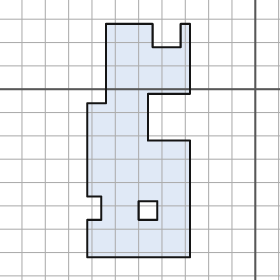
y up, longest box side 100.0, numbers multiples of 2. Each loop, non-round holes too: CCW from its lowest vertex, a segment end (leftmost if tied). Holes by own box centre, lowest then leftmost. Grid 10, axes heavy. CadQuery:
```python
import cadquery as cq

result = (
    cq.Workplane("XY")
    .moveTo(-72.0, -72.0)
    .lineTo(-28.0, -72.0)
    .lineTo(-28.0, -22.0)
    .lineTo(-46.0, -22.0)
    .lineTo(-46.0, -2.0)
    .lineTo(-28.0, -2.0)
    .lineTo(-28.0, 28.0)
    .lineTo(-32.0, 28.0)
    .lineTo(-32.0, 18.0)
    .lineTo(-44.0, 18.0)
    .lineTo(-44.0, 28.0)
    .lineTo(-64.0, 28.0)
    .lineTo(-64.0, -6.0)
    .lineTo(-72.0, -6.0)
    .lineTo(-72.0, -46.0)
    .lineTo(-66.0, -46.0)
    .lineTo(-66.0, -56.0)
    .lineTo(-72.0, -56.0)
    .close()
    .moveTo(-50.0, -56.0)
    .lineTo(-42.0, -56.0)
    .lineTo(-42.0, -48.0)
    .lineTo(-50.0, -48.0)
    .close()
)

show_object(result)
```